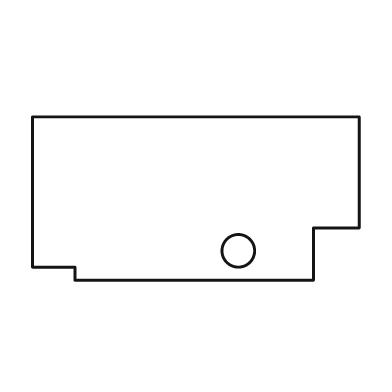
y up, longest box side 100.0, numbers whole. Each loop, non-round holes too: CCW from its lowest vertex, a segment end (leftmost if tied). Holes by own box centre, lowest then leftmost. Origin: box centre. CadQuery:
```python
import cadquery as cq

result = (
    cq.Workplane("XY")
    .moveTo(-37.0, -25.0)
    .lineTo(36.0, -25.0)
    .lineTo(36.0, -9.0)
    .lineTo(50.0, -9.0)
    .lineTo(50.0, 25.0)
    .lineTo(-50.0, 25.0)
    .lineTo(-50.0, -21.0)
    .lineTo(-37.0, -21.0)
    .close()
    .moveTo(13.0, -16.0)
    .circle(5.0)
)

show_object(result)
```